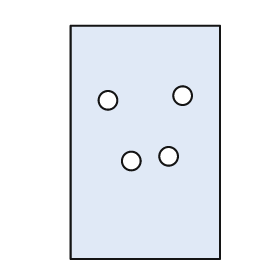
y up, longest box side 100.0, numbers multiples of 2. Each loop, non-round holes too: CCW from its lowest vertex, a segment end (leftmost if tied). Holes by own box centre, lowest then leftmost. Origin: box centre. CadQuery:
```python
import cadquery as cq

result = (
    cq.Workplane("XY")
    .moveTo(-32.0, -50.0)
    .lineTo(32.0, -50.0)
    .lineTo(32.0, 50.0)
    .lineTo(-32.0, 50.0)
    .close()
    .moveTo(-6.0, -8.0)
    .circle(4.0)
    .moveTo(10.0, -6.0)
    .circle(4.0)
    .moveTo(-16.0, 18.0)
    .circle(4.0)
    .moveTo(16.0, 20.0)
    .circle(4.0)
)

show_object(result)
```